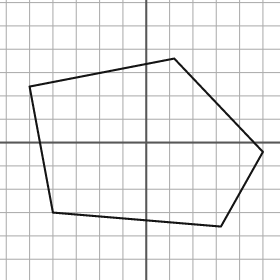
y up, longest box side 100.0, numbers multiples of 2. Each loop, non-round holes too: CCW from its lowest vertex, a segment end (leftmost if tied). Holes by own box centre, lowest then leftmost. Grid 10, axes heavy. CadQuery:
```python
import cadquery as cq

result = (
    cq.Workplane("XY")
    .moveTo(32.0, -36.0)
    .lineTo(50.0, -4.0)
    .lineTo(12.0, 36.0)
    .lineTo(-50.0, 24.0)
    .lineTo(-40.0, -30.0)
    .close()
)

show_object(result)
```